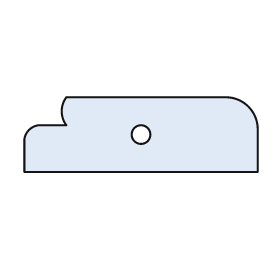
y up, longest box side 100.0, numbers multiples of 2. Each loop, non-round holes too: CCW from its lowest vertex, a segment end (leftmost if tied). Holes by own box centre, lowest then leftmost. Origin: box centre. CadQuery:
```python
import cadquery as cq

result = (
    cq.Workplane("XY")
    .moveTo(-50.0, -16.0)
    .lineTo(50.0, -16.0)
    .lineTo(50.0, 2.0)
    .threePointArc((46.0, 12.0), (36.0, 16.0))
    .lineTo(-32.0, 16.0)
    .threePointArc((-34.0, 10.0), (-32.0, 4.0))
    .lineTo(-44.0, 4.0)
    .threePointArc((-48.0, 2.0), (-50.0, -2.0))
    .close()
    .moveTo(0.0, 0.0)
    .circle(4.0)
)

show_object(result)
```